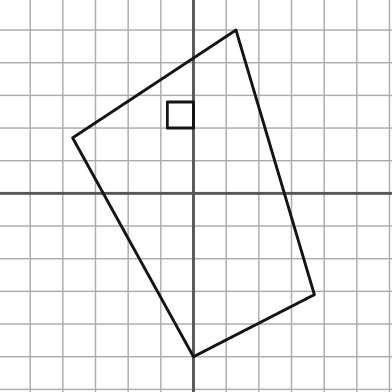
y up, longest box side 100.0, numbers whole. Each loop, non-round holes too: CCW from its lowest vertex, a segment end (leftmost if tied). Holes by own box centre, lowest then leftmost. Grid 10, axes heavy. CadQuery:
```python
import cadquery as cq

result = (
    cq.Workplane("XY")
    .moveTo(0.0, -50.0)
    .lineTo(37.0, -31.0)
    .lineTo(13.0, 50.0)
    .lineTo(-37.0, 17.0)
    .close()
    .moveTo(-8.0, 20.0)
    .lineTo(0.0, 20.0)
    .lineTo(0.0, 28.0)
    .lineTo(-8.0, 28.0)
    .close()
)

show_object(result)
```